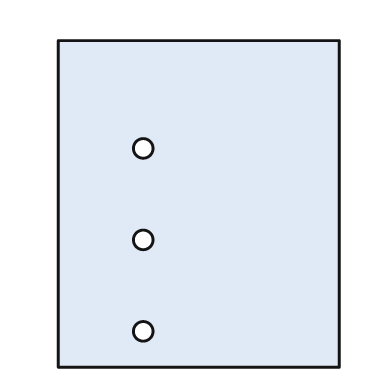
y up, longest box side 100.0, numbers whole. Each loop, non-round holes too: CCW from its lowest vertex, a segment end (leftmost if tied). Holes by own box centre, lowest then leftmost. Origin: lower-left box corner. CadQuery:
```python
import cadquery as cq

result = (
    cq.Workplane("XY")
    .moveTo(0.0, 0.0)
    .lineTo(86.0, 0.0)
    .lineTo(86.0, 100.0)
    .lineTo(0.0, 100.0)
    .close()
    .moveTo(26.0, 11.0)
    .circle(3.0)
    .moveTo(26.0, 39.0)
    .circle(3.0)
    .moveTo(26.0, 67.0)
    .circle(3.0)
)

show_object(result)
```